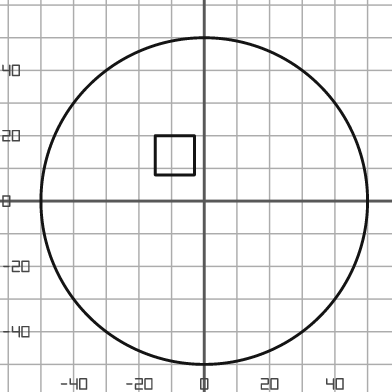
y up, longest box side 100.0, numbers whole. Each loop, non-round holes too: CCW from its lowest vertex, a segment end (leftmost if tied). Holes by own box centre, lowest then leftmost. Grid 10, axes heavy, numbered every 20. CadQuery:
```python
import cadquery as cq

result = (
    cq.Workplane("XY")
    .moveTo(0.0, 0.0)
    .circle(50.0)
    .moveTo(-15.0, 8.0)
    .lineTo(-3.0, 8.0)
    .lineTo(-3.0, 20.0)
    .lineTo(-15.0, 20.0)
    .close()
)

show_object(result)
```